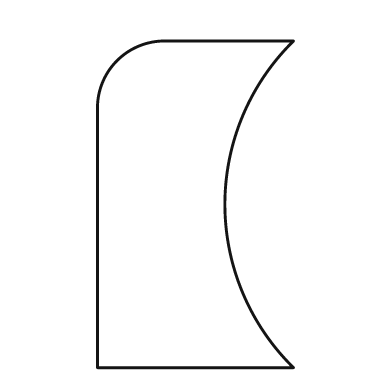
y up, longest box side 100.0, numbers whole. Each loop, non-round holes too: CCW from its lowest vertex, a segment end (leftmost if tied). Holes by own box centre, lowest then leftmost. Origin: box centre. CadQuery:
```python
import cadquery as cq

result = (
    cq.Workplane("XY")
    .moveTo(-30.0, -50.0)
    .lineTo(30.0, -50.0)
    .threePointArc((9.0, 0.0), (30.0, 50.0))
    .lineTo(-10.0, 50.0)
    .threePointArc((-24.0, 44.0), (-30.0, 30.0))
    .close()
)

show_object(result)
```